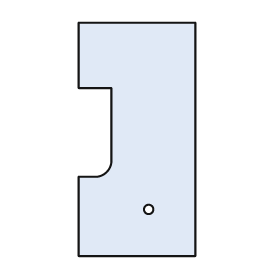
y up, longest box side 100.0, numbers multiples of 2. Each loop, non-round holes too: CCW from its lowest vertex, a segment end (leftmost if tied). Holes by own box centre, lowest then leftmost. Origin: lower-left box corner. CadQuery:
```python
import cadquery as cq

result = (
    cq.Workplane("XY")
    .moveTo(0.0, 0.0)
    .lineTo(50.0, 0.0)
    .lineTo(50.0, 100.0)
    .lineTo(0.0, 100.0)
    .lineTo(0.0, 72.0)
    .lineTo(14.0, 72.0)
    .lineTo(14.0, 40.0)
    .threePointArc((12.0, 36.0), (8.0, 34.0))
    .lineTo(0.0, 34.0)
    .close()
    .moveTo(30.0, 20.0)
    .circle(2.0)
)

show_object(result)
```